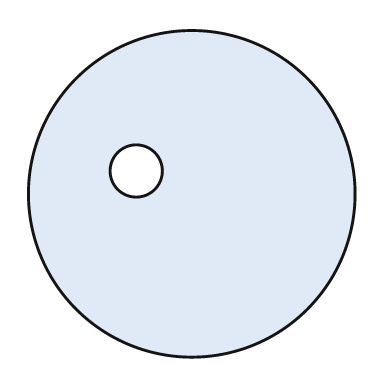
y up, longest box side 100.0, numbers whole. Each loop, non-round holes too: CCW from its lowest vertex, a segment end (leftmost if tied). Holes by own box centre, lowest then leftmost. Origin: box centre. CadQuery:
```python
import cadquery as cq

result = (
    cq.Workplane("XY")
    .moveTo(0.0, 0.0)
    .circle(50.0)
    .moveTo(-17.0, 7.0)
    .circle(8.0)
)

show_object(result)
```